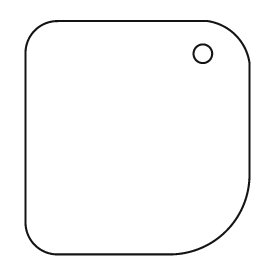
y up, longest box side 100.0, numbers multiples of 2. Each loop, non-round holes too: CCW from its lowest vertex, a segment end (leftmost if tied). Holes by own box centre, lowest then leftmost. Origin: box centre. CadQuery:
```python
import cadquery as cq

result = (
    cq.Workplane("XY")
    .moveTo(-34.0, -50.0)
    .lineTo(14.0, -50.0)
    .threePointArc((38.0, -40.0), (48.0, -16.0))
    .lineTo(48.0, 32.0)
    .threePointArc((42.0, 44.0), (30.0, 50.0))
    .lineTo(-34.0, 50.0)
    .threePointArc((-44.0, 46.0), (-48.0, 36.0))
    .lineTo(-48.0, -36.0)
    .threePointArc((-44.0, -46.0), (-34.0, -50.0))
    .close()
    .moveTo(28.0, 36.0)
    .circle(4.0)
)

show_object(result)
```